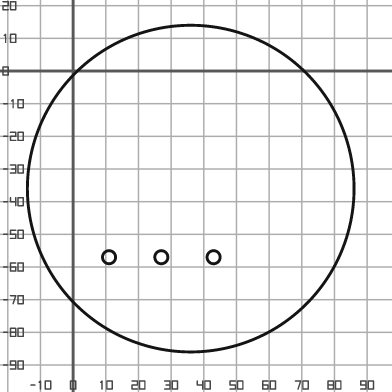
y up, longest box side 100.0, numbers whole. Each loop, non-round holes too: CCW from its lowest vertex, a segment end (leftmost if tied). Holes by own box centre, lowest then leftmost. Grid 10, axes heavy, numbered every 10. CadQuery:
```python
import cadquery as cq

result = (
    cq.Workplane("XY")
    .moveTo(36.0, -36.0)
    .circle(50.0)
    .moveTo(11.0, -57.0)
    .circle(2.0)
    .moveTo(27.0, -57.0)
    .circle(2.0)
    .moveTo(43.0, -57.0)
    .circle(2.0)
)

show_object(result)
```